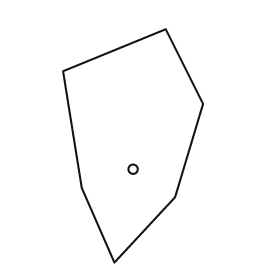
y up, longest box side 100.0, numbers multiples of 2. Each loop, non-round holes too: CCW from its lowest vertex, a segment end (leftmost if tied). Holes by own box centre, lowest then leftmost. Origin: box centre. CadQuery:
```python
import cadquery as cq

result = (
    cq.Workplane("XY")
    .moveTo(-8.0, -50.0)
    .lineTo(18.0, -22.0)
    .lineTo(30.0, 18.0)
    .lineTo(14.0, 50.0)
    .lineTo(-30.0, 32.0)
    .lineTo(-22.0, -18.0)
    .close()
    .moveTo(0.0, -10.0)
    .circle(2.0)
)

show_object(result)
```